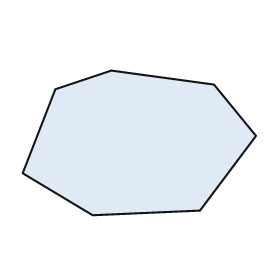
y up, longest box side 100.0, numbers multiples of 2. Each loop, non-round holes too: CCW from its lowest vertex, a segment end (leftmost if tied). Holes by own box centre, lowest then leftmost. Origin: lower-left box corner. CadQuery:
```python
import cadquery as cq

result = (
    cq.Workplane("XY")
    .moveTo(30.0, 0.0)
    .lineTo(76.0, 2.0)
    .lineTo(100.0, 34.0)
    .lineTo(82.0, 56.0)
    .lineTo(38.0, 62.0)
    .lineTo(14.0, 54.0)
    .lineTo(0.0, 18.0)
    .close()
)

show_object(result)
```